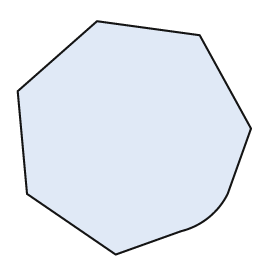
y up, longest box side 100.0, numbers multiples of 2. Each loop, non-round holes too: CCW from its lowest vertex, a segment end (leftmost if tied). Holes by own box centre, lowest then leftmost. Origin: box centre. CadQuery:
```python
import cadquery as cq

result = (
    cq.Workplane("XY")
    .moveTo(-8.0, -50.0)
    .lineTo(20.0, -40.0)
    .threePointArc((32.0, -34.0), (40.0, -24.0))
    .lineTo(50.0, 4.0)
    .lineTo(28.0, 44.0)
    .lineTo(-16.0, 50.0)
    .lineTo(-50.0, 20.0)
    .lineTo(-46.0, -24.0)
    .close()
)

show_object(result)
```